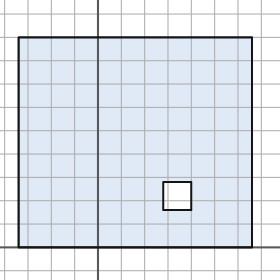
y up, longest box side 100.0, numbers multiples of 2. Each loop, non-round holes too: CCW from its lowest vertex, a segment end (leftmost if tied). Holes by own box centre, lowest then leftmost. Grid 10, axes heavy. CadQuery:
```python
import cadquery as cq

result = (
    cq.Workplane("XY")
    .moveTo(-34.0, 0.0)
    .lineTo(66.0, 0.0)
    .lineTo(66.0, 90.0)
    .lineTo(-34.0, 90.0)
    .close()
    .moveTo(28.0, 16.0)
    .lineTo(40.0, 16.0)
    .lineTo(40.0, 28.0)
    .lineTo(28.0, 28.0)
    .close()
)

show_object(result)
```